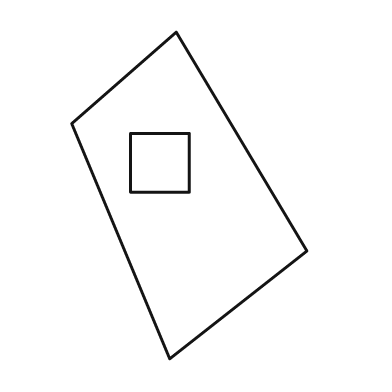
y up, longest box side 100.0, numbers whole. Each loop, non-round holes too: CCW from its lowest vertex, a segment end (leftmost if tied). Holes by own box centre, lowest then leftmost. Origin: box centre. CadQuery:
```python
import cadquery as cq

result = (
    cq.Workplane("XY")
    .moveTo(-6.0, -50.0)
    .lineTo(36.0, -17.0)
    .lineTo(-4.0, 50.0)
    .lineTo(-36.0, 22.0)
    .close()
    .moveTo(-18.0, 1.0)
    .lineTo(0.0, 1.0)
    .lineTo(0.0, 19.0)
    .lineTo(-18.0, 19.0)
    .close()
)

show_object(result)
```